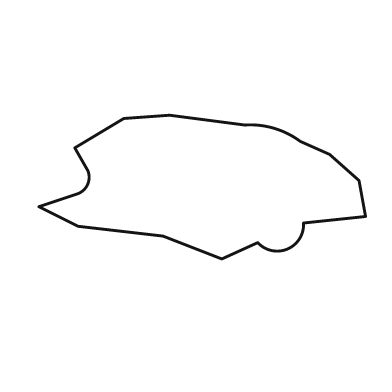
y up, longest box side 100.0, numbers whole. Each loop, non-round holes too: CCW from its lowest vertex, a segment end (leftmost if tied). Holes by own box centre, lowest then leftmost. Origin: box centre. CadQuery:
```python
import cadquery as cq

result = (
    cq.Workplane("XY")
    .moveTo(6.0, -22.0)
    .lineTo(17.0, -17.0)
    .threePointArc((26.0, -19.0), (31.0, -11.0))
    .lineTo(50.0, -9.0)
    .lineTo(48.0, 2.0)
    .lineTo(39.0, 10.0)
    .lineTo(30.0, 14.0)
    .threePointArc((22.0, 18.0), (13.0, 19.0))
    .lineTo(-10.0, 22.0)
    .lineTo(-24.0, 21.0)
    .lineTo(-39.0, 12.0)
    .lineTo(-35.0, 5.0)
    .threePointArc((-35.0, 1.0), (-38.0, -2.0))
    .lineTo(-50.0, -6.0)
    .lineTo(-38.0, -12.0)
    .lineTo(-12.0, -15.0)
    .close()
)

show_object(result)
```